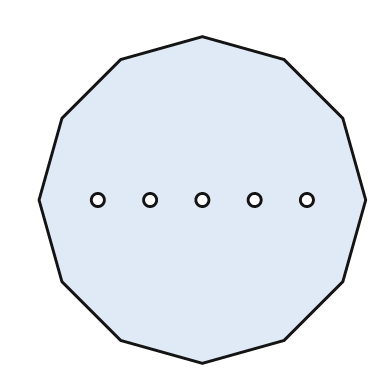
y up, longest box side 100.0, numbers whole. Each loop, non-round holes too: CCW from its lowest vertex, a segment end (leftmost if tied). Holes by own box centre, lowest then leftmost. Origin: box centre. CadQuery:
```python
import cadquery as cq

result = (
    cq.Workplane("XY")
    .moveTo(0.0, -50.0)
    .lineTo(25.0, -43.0)
    .lineTo(43.0, -25.0)
    .lineTo(50.0, 0.0)
    .lineTo(43.0, 25.0)
    .lineTo(25.0, 43.0)
    .lineTo(0.0, 50.0)
    .lineTo(-25.0, 43.0)
    .lineTo(-43.0, 25.0)
    .lineTo(-50.0, 0.0)
    .lineTo(-43.0, -25.0)
    .lineTo(-25.0, -43.0)
    .close()
    .moveTo(-32.0, 0.0)
    .circle(2.0)
    .moveTo(-16.0, 0.0)
    .circle(2.0)
    .moveTo(0.0, 0.0)
    .circle(2.0)
    .moveTo(16.0, 0.0)
    .circle(2.0)
    .moveTo(32.0, 0.0)
    .circle(2.0)
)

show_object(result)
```